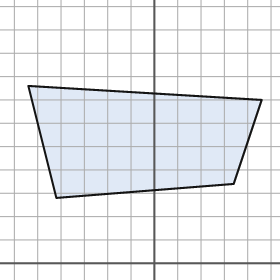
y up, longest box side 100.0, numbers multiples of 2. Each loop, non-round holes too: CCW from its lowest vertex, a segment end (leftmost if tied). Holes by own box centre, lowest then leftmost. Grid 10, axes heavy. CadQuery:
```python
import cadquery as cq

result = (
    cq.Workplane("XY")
    .moveTo(-42.0, 28.0)
    .lineTo(34.0, 34.0)
    .lineTo(46.0, 70.0)
    .lineTo(-54.0, 76.0)
    .close()
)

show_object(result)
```